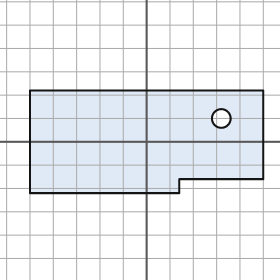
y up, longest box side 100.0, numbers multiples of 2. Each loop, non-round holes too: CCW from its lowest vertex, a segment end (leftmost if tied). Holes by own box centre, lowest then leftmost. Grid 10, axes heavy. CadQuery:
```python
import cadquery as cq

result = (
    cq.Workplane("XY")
    .moveTo(-50.0, -22.0)
    .lineTo(14.0, -22.0)
    .lineTo(14.0, -16.0)
    .lineTo(50.0, -16.0)
    .lineTo(50.0, 22.0)
    .lineTo(-50.0, 22.0)
    .close()
    .moveTo(32.0, 10.0)
    .circle(4.0)
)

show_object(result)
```